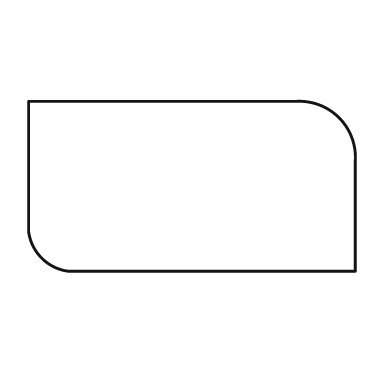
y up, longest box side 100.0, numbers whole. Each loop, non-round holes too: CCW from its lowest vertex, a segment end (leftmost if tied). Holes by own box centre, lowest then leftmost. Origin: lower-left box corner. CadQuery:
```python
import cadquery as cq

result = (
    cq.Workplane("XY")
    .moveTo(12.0, 0.0)
    .lineTo(100.0, 0.0)
    .lineTo(100.0, 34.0)
    .threePointArc((95.0, 47.0), (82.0, 52.0))
    .lineTo(0.0, 52.0)
    .lineTo(0.0, 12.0)
    .threePointArc((4.0, 4.0), (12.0, 0.0))
    .close()
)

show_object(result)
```